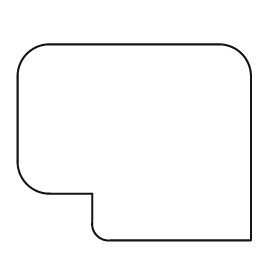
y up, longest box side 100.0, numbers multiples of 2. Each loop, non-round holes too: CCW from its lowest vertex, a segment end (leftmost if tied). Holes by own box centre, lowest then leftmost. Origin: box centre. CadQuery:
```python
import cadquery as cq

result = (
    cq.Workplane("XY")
    .moveTo(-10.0, -42.0)
    .lineTo(50.0, -42.0)
    .lineTo(50.0, 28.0)
    .threePointArc((46.0, 38.0), (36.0, 42.0))
    .lineTo(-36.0, 42.0)
    .threePointArc((-46.0, 38.0), (-50.0, 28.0))
    .lineTo(-50.0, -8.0)
    .threePointArc((-46.0, -18.0), (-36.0, -22.0))
    .lineTo(-18.0, -22.0)
    .lineTo(-18.0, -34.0)
    .threePointArc((-16.0, -40.0), (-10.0, -42.0))
    .close()
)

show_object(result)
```